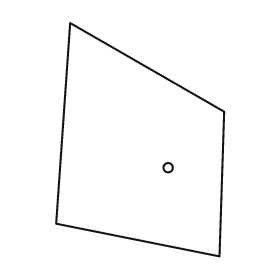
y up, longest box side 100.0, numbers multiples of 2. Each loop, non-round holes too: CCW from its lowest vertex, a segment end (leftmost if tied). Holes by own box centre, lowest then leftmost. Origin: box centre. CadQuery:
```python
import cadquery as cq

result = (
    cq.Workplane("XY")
    .moveTo(34.0, -50.0)
    .lineTo(36.0, 12.0)
    .lineTo(-30.0, 50.0)
    .lineTo(-36.0, -36.0)
    .close()
    .moveTo(12.0, -12.0)
    .circle(2.0)
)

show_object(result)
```